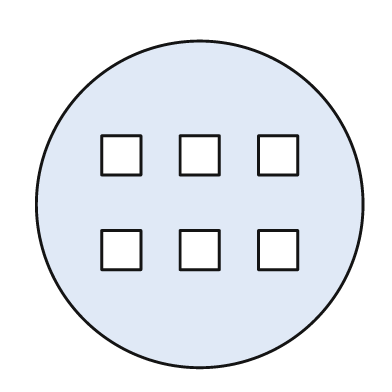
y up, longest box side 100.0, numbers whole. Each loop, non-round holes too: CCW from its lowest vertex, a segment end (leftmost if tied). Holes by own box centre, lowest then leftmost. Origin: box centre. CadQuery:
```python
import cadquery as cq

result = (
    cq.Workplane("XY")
    .moveTo(0.0, 0.0)
    .circle(50.0)
    .moveTo(-30.0, -20.0)
    .lineTo(-18.0, -20.0)
    .lineTo(-18.0, -8.0)
    .lineTo(-30.0, -8.0)
    .close()
    .moveTo(-6.0, -20.0)
    .lineTo(6.0, -20.0)
    .lineTo(6.0, -8.0)
    .lineTo(-6.0, -8.0)
    .close()
    .moveTo(18.0, -20.0)
    .lineTo(30.0, -20.0)
    .lineTo(30.0, -8.0)
    .lineTo(18.0, -8.0)
    .close()
    .moveTo(-30.0, 9.0)
    .lineTo(-18.0, 9.0)
    .lineTo(-18.0, 21.0)
    .lineTo(-30.0, 21.0)
    .close()
    .moveTo(-6.0, 9.0)
    .lineTo(6.0, 9.0)
    .lineTo(6.0, 21.0)
    .lineTo(-6.0, 21.0)
    .close()
    .moveTo(18.0, 9.0)
    .lineTo(30.0, 9.0)
    .lineTo(30.0, 21.0)
    .lineTo(18.0, 21.0)
    .close()
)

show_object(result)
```